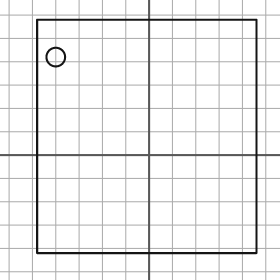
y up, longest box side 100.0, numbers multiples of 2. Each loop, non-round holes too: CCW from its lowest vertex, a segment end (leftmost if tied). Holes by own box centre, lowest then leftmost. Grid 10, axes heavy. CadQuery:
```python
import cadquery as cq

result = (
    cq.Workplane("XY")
    .moveTo(-48.0, -42.0)
    .lineTo(46.0, -42.0)
    .lineTo(46.0, 58.0)
    .lineTo(-48.0, 58.0)
    .close()
    .moveTo(-40.0, 42.0)
    .circle(4.0)
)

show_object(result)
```